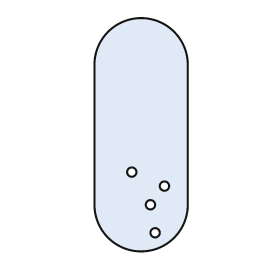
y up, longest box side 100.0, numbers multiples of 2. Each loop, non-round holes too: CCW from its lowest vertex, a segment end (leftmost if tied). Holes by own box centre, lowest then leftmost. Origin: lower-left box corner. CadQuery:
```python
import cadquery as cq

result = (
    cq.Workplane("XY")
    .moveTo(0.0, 20.0)
    .threePointArc((20.0, 0.0), (40.0, 20.0))
    .lineTo(40.0, 80.0)
    .threePointArc((20.0, 100.0), (0.0, 80.0))
    .close()
    .moveTo(26.0, 8.0)
    .circle(2.0)
    .moveTo(24.0, 20.0)
    .circle(2.0)
    .moveTo(30.0, 28.0)
    .circle(2.0)
    .moveTo(16.0, 34.0)
    .circle(2.0)
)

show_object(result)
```